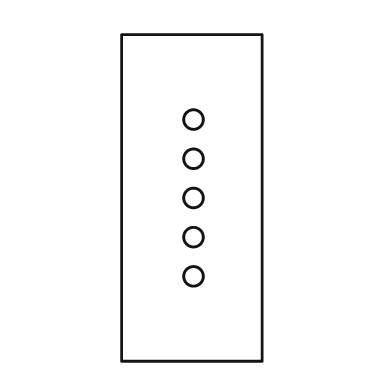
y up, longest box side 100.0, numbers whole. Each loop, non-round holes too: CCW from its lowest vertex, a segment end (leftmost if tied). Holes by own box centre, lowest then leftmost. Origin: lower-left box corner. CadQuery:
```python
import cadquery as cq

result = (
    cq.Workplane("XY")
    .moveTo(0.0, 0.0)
    .lineTo(43.0, 0.0)
    .lineTo(43.0, 100.0)
    .lineTo(0.0, 100.0)
    .close()
    .moveTo(22.0, 26.0)
    .circle(3.0)
    .moveTo(22.0, 38.0)
    .circle(3.0)
    .moveTo(22.0, 50.0)
    .circle(3.0)
    .moveTo(22.0, 62.0)
    .circle(3.0)
    .moveTo(22.0, 74.0)
    .circle(3.0)
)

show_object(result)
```